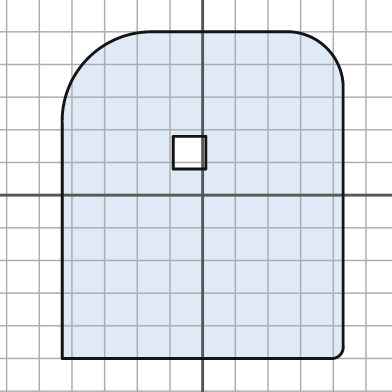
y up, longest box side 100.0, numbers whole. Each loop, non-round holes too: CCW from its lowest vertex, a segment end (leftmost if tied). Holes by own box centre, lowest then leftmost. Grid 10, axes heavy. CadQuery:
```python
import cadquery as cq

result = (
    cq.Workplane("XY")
    .moveTo(-43.0, -50.0)
    .lineTo(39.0, -50.0)
    .threePointArc((42.0, -49.0), (43.0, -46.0))
    .lineTo(43.0, 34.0)
    .threePointArc((38.0, 45.0), (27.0, 50.0))
    .lineTo(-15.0, 50.0)
    .threePointArc((-35.0, 42.0), (-43.0, 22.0))
    .close()
    .moveTo(-9.0, 8.0)
    .lineTo(1.0, 8.0)
    .lineTo(1.0, 18.0)
    .lineTo(-9.0, 18.0)
    .close()
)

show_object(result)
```